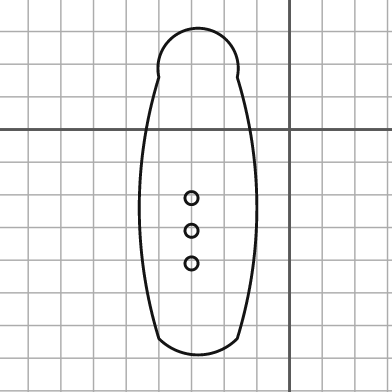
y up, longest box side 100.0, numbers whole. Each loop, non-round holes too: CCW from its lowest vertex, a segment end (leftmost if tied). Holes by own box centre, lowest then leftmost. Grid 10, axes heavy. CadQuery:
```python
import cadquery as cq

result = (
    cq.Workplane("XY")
    .moveTo(-40.0, -64.0)
    .threePointArc((-28.0, -69.0), (-16.0, -64.0))
    .threePointArc((-10.0, -24.0), (-16.0, 16.0))
    .threePointArc((-28.0, 31.0), (-40.0, 16.0))
    .threePointArc((-46.0, -24.0), (-40.0, -64.0))
    .close()
    .moveTo(-30.0, -41.0)
    .circle(2.0)
    .moveTo(-30.0, -31.0)
    .circle(2.0)
    .moveTo(-30.0, -21.0)
    .circle(2.0)
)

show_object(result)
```